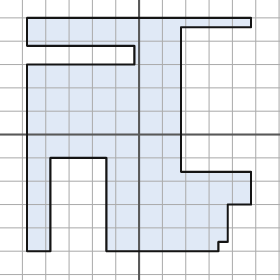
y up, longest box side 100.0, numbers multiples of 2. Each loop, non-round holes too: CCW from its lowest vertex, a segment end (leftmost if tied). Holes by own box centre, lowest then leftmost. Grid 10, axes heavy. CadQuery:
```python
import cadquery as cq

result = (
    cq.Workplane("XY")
    .moveTo(-48.0, -50.0)
    .lineTo(-38.0, -50.0)
    .lineTo(-38.0, -10.0)
    .lineTo(-14.0, -10.0)
    .lineTo(-14.0, -50.0)
    .lineTo(34.0, -50.0)
    .lineTo(34.0, -46.0)
    .lineTo(38.0, -46.0)
    .lineTo(38.0, -30.0)
    .lineTo(48.0, -30.0)
    .lineTo(48.0, -16.0)
    .lineTo(18.0, -16.0)
    .lineTo(18.0, 46.0)
    .lineTo(48.0, 46.0)
    .lineTo(48.0, 50.0)
    .lineTo(-48.0, 50.0)
    .lineTo(-48.0, 38.0)
    .lineTo(-2.0, 38.0)
    .lineTo(-2.0, 30.0)
    .lineTo(-48.0, 30.0)
    .close()
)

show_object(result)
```